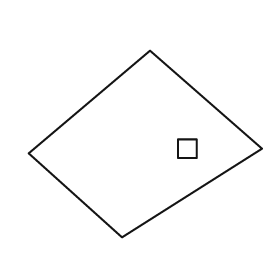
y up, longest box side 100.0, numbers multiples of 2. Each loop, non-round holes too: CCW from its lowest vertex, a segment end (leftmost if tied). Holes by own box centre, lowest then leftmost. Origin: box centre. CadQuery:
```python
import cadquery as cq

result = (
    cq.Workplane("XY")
    .moveTo(-10.0, -40.0)
    .lineTo(50.0, -2.0)
    .lineTo(2.0, 40.0)
    .lineTo(-50.0, -4.0)
    .close()
    .moveTo(14.0, -6.0)
    .lineTo(22.0, -6.0)
    .lineTo(22.0, 2.0)
    .lineTo(14.0, 2.0)
    .close()
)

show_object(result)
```